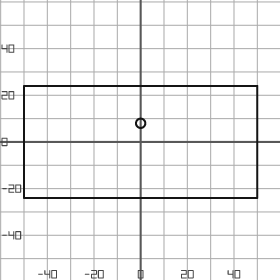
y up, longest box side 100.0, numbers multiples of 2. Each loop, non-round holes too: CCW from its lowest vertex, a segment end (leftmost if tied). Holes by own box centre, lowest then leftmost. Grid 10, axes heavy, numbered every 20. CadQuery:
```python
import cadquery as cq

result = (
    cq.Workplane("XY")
    .moveTo(-50.0, -24.0)
    .lineTo(50.0, -24.0)
    .lineTo(50.0, 24.0)
    .lineTo(-50.0, 24.0)
    .close()
    .moveTo(0.0, 8.0)
    .circle(2.0)
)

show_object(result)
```